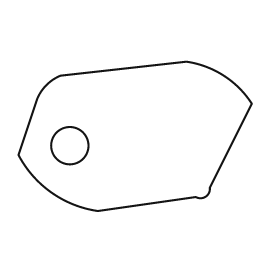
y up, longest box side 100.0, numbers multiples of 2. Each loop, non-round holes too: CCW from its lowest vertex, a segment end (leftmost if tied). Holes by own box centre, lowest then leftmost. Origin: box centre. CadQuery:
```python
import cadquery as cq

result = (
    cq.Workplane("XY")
    .moveTo(-16.0, -32.0)
    .lineTo(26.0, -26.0)
    .threePointArc((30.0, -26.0), (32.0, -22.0))
    .lineTo(50.0, 14.0)
    .threePointArc((38.0, 26.0), (22.0, 32.0))
    .lineTo(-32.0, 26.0)
    .threePointArc((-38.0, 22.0), (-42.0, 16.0))
    .lineTo(-50.0, -8.0)
    .threePointArc((-36.0, -24.0), (-16.0, -32.0))
    .close()
    .moveTo(-28.0, -4.0)
    .circle(8.0)
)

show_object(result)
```